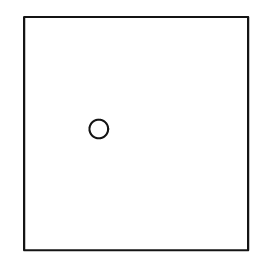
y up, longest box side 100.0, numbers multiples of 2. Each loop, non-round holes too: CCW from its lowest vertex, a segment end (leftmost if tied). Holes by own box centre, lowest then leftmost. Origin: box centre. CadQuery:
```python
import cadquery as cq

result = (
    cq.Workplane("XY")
    .moveTo(-48.0, -50.0)
    .lineTo(48.0, -50.0)
    .lineTo(48.0, 50.0)
    .lineTo(-48.0, 50.0)
    .close()
    .moveTo(-16.0, 2.0)
    .circle(4.0)
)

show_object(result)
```